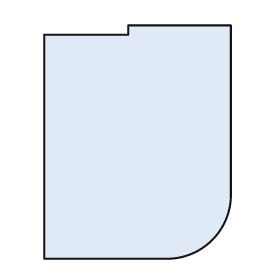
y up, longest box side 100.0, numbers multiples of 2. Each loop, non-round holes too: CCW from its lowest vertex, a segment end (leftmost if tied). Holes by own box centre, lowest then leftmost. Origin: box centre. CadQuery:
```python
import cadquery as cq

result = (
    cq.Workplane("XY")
    .moveTo(-40.0, -50.0)
    .lineTo(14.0, -50.0)
    .threePointArc((32.0, -42.0), (40.0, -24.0))
    .lineTo(40.0, 50.0)
    .lineTo(-4.0, 50.0)
    .lineTo(-4.0, 46.0)
    .lineTo(-40.0, 46.0)
    .close()
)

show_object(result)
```